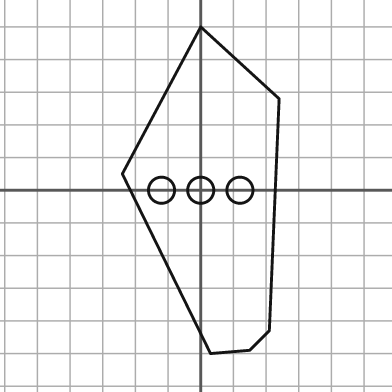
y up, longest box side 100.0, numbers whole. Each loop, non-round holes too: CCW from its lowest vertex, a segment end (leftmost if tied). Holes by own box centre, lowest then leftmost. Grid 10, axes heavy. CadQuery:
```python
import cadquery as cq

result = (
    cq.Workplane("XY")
    .moveTo(3.0, -50.0)
    .lineTo(15.0, -49.0)
    .lineTo(21.0, -43.0)
    .lineTo(24.0, 28.0)
    .lineTo(0.0, 50.0)
    .lineTo(-24.0, 5.0)
    .close()
    .moveTo(-12.0, 0.0)
    .circle(4.0)
    .moveTo(0.0, 0.0)
    .circle(4.0)
    .moveTo(12.0, 0.0)
    .circle(4.0)
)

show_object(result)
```